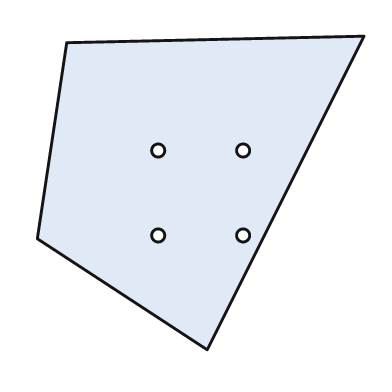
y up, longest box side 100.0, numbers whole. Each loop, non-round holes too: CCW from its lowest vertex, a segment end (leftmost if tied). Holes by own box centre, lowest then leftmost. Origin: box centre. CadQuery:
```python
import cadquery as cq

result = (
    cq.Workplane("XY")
    .moveTo(2.0, -48.0)
    .lineTo(50.0, 48.0)
    .lineTo(-41.0, 46.0)
    .lineTo(-50.0, -14.0)
    .close()
    .moveTo(-13.0, -13.0)
    .circle(2.0)
    .moveTo(13.0, -13.0)
    .circle(2.0)
    .moveTo(-13.0, 13.0)
    .circle(2.0)
    .moveTo(13.0, 13.0)
    .circle(2.0)
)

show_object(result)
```